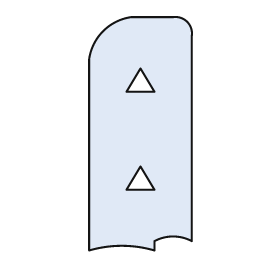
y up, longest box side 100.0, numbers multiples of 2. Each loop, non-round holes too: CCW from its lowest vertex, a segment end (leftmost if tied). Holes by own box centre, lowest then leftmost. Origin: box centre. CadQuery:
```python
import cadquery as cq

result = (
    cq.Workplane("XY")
    .moveTo(-22.0, -50.0)
    .threePointArc((-8.0, -48.0), (6.0, -50.0))
    .lineTo(6.0, -46.0)
    .threePointArc((14.0, -44.0), (22.0, -46.0))
    .lineTo(22.0, 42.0)
    .threePointArc((20.0, 48.0), (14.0, 50.0))
    .lineTo(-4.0, 50.0)
    .threePointArc((-16.0, 44.0), (-22.0, 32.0))
    .close()
    .moveTo(-6.0, -24.0)
    .lineTo(6.0, -24.0)
    .lineTo(0.0, -14.0)
    .close()
    .moveTo(-6.0, 18.0)
    .lineTo(6.0, 18.0)
    .lineTo(0.0, 28.0)
    .close()
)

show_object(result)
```